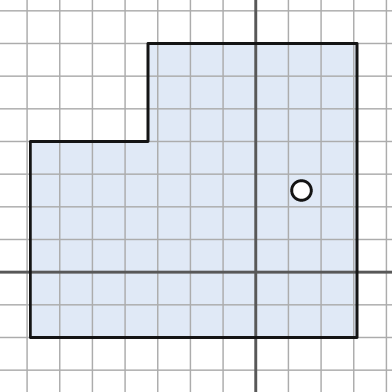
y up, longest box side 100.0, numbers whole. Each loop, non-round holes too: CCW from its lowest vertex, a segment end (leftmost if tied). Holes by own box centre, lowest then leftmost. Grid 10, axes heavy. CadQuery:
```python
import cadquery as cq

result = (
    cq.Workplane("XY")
    .moveTo(-69.0, -20.0)
    .lineTo(31.0, -20.0)
    .lineTo(31.0, 70.0)
    .lineTo(-33.0, 70.0)
    .lineTo(-33.0, 40.0)
    .lineTo(-69.0, 40.0)
    .close()
    .moveTo(14.0, 25.0)
    .circle(3.0)
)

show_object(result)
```